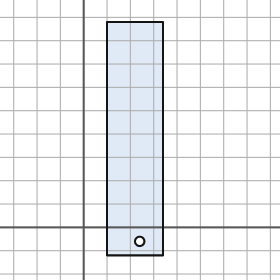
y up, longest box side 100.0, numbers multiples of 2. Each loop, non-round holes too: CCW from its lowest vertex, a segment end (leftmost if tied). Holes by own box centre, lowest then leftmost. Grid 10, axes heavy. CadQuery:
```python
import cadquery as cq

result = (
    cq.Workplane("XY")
    .moveTo(10.0, -12.0)
    .lineTo(34.0, -12.0)
    .lineTo(34.0, 88.0)
    .lineTo(10.0, 88.0)
    .close()
    .moveTo(24.0, -6.0)
    .circle(2.0)
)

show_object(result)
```